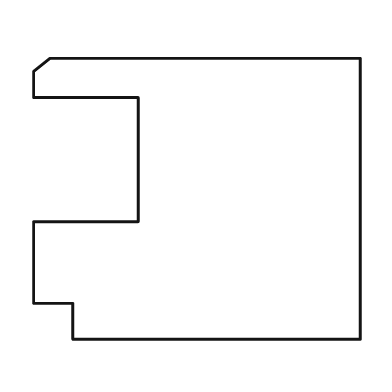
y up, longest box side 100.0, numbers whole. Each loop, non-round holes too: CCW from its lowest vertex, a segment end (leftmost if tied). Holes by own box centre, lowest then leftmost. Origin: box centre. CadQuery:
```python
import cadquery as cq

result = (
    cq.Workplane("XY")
    .moveTo(-38.0, -43.0)
    .lineTo(50.0, -43.0)
    .lineTo(50.0, 43.0)
    .lineTo(-45.0, 43.0)
    .lineTo(-50.0, 39.0)
    .lineTo(-50.0, 31.0)
    .lineTo(-18.0, 31.0)
    .lineTo(-18.0, -7.0)
    .lineTo(-50.0, -7.0)
    .lineTo(-50.0, -32.0)
    .lineTo(-38.0, -32.0)
    .close()
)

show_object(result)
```